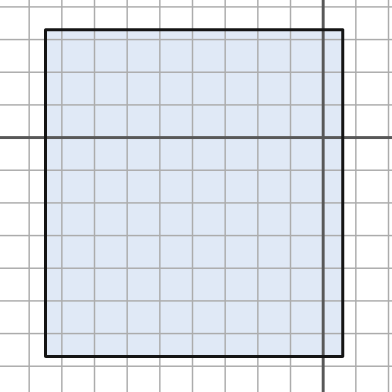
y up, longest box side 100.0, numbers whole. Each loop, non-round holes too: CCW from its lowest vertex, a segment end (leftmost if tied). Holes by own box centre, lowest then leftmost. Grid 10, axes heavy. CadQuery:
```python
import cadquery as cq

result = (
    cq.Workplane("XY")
    .moveTo(-85.0, -67.0)
    .lineTo(6.0, -67.0)
    .lineTo(6.0, 33.0)
    .lineTo(-85.0, 33.0)
    .close()
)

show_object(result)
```